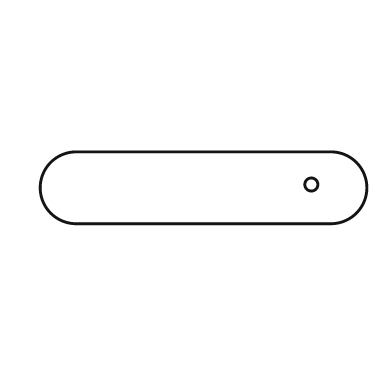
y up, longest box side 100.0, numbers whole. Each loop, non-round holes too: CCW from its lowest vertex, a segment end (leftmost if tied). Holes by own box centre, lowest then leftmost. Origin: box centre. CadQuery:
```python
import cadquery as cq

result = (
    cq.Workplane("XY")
    .moveTo(-39.0, -11.0)
    .lineTo(39.0, -11.0)
    .threePointArc((50.0, 0.0), (39.0, 11.0))
    .lineTo(-39.0, 11.0)
    .threePointArc((-50.0, 0.0), (-39.0, -11.0))
    .close()
    .moveTo(33.0, 1.0)
    .circle(2.0)
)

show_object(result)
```